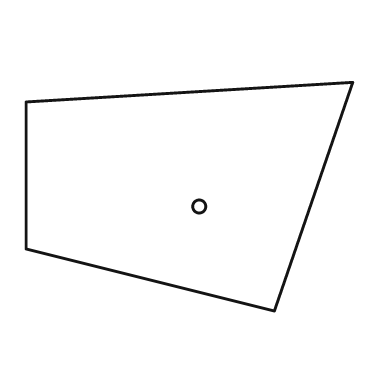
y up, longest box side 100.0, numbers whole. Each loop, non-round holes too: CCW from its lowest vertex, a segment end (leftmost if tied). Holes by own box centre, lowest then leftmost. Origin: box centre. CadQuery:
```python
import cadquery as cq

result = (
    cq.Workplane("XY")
    .moveTo(26.0, -35.0)
    .lineTo(50.0, 35.0)
    .lineTo(-50.0, 29.0)
    .lineTo(-50.0, -16.0)
    .close()
    .moveTo(3.0, -3.0)
    .circle(2.0)
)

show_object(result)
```